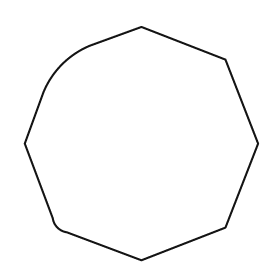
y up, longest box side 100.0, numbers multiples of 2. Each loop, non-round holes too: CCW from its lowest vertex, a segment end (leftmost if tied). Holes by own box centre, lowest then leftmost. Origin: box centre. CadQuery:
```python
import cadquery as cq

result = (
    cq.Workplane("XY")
    .moveTo(0.0, -50.0)
    .lineTo(36.0, -36.0)
    .lineTo(50.0, 0.0)
    .lineTo(36.0, 36.0)
    .lineTo(0.0, 50.0)
    .lineTo(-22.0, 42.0)
    .threePointArc((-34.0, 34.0), (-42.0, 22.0))
    .lineTo(-50.0, 0.0)
    .lineTo(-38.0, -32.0)
    .threePointArc((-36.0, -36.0), (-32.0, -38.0))
    .close()
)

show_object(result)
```